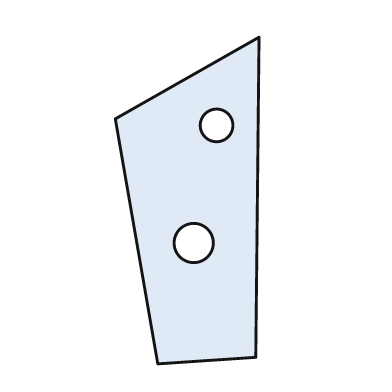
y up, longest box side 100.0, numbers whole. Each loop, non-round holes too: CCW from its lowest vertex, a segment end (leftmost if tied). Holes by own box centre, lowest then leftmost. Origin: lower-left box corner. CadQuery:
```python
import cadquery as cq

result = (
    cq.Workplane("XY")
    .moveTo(13.0, 0.0)
    .lineTo(43.0, 2.0)
    .lineTo(44.0, 100.0)
    .lineTo(0.0, 75.0)
    .close()
    .moveTo(24.0, 37.0)
    .circle(6.0)
    .moveTo(31.0, 73.0)
    .circle(5.0)
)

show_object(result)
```